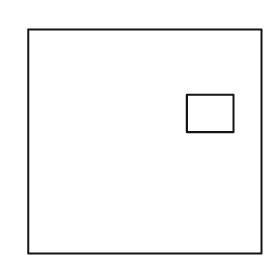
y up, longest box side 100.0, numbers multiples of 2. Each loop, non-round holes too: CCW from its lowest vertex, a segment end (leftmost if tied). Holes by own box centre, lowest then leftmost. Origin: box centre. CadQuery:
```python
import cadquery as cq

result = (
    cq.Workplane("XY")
    .moveTo(-50.0, -48.0)
    .lineTo(50.0, -48.0)
    .lineTo(50.0, 48.0)
    .lineTo(-50.0, 48.0)
    .close()
    .moveTo(18.0, 4.0)
    .lineTo(38.0, 4.0)
    .lineTo(38.0, 20.0)
    .lineTo(18.0, 20.0)
    .close()
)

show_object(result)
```